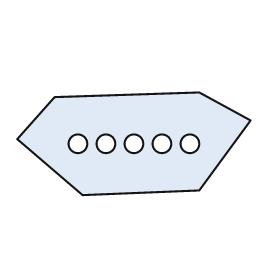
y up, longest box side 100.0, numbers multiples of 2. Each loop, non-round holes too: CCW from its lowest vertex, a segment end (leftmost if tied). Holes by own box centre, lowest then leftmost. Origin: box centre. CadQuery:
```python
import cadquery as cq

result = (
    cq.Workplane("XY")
    .moveTo(-22.0, -22.0)
    .lineTo(28.0, -20.0)
    .lineTo(50.0, 10.0)
    .lineTo(28.0, 22.0)
    .lineTo(-34.0, 20.0)
    .lineTo(-50.0, 2.0)
    .close()
    .moveTo(-24.0, 0.0)
    .circle(4.0)
    .moveTo(-12.0, 0.0)
    .circle(4.0)
    .moveTo(0.0, 0.0)
    .circle(4.0)
    .moveTo(12.0, 0.0)
    .circle(4.0)
    .moveTo(24.0, 0.0)
    .circle(4.0)
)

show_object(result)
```